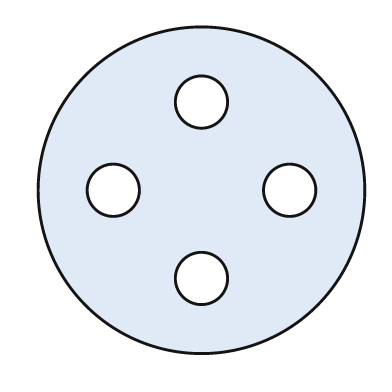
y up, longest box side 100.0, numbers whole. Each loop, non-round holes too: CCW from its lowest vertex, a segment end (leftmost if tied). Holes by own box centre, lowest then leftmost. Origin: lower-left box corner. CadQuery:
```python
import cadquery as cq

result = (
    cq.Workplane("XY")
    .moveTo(50.0, 50.0)
    .circle(50.0)
    .moveTo(50.0, 23.0)
    .circle(8.0)
    .moveTo(23.0, 50.0)
    .circle(8.0)
    .moveTo(77.0, 50.0)
    .circle(8.0)
    .moveTo(50.0, 77.0)
    .circle(8.0)
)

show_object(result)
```